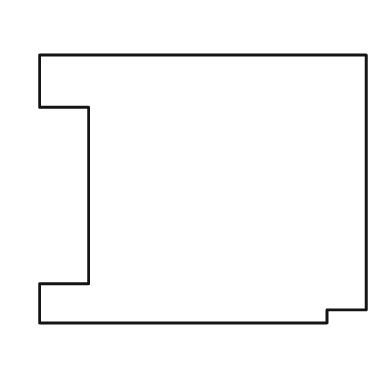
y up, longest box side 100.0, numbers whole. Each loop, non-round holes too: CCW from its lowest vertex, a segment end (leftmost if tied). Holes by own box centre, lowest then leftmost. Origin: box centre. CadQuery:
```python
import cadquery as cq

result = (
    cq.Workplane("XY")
    .moveTo(-50.0, -41.0)
    .lineTo(38.0, -41.0)
    .lineTo(38.0, -37.0)
    .lineTo(50.0, -37.0)
    .lineTo(50.0, 41.0)
    .lineTo(-50.0, 41.0)
    .lineTo(-50.0, 25.0)
    .lineTo(-35.0, 25.0)
    .lineTo(-35.0, -29.0)
    .lineTo(-50.0, -29.0)
    .close()
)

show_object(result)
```